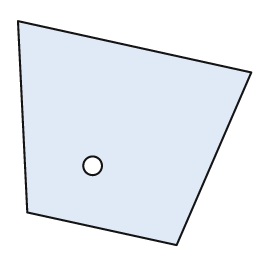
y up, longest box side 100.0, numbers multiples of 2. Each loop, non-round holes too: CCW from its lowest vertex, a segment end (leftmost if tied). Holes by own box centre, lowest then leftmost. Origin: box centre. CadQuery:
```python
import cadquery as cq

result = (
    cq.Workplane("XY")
    .moveTo(18.0, -48.0)
    .lineTo(50.0, 26.0)
    .lineTo(-50.0, 48.0)
    .lineTo(-46.0, -34.0)
    .close()
    .moveTo(-18.0, -14.0)
    .circle(4.0)
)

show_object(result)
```